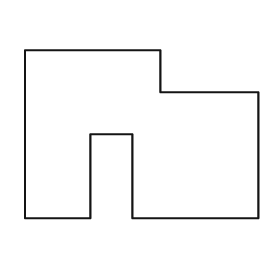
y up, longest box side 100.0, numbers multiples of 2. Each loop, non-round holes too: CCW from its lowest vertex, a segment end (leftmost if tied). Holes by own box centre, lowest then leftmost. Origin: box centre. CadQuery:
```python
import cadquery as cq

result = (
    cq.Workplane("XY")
    .moveTo(-50.0, -36.0)
    .lineTo(-22.0, -36.0)
    .lineTo(-22.0, 0.0)
    .lineTo(-4.0, 0.0)
    .lineTo(-4.0, -36.0)
    .lineTo(50.0, -36.0)
    .lineTo(50.0, 18.0)
    .lineTo(8.0, 18.0)
    .lineTo(8.0, 36.0)
    .lineTo(-50.0, 36.0)
    .close()
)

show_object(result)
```